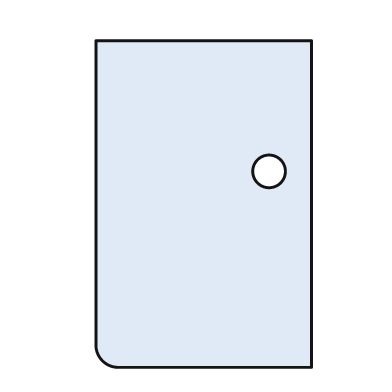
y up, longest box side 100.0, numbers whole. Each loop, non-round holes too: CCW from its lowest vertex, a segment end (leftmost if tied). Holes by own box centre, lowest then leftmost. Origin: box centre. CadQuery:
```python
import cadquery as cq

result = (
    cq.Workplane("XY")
    .moveTo(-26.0, -50.0)
    .lineTo(33.0, -50.0)
    .lineTo(33.0, 50.0)
    .lineTo(-33.0, 50.0)
    .lineTo(-33.0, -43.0)
    .threePointArc((-31.0, -48.0), (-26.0, -50.0))
    .close()
    .moveTo(20.0, 10.0)
    .circle(5.0)
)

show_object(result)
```